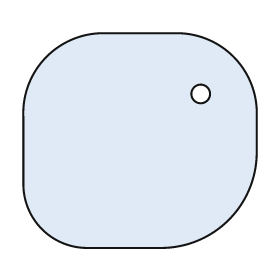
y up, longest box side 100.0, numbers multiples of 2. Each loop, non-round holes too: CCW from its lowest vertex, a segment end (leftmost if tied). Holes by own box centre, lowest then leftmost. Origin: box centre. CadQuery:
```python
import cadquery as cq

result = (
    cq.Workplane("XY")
    .moveTo(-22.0, -46.0)
    .lineTo(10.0, -46.0)
    .threePointArc((38.0, -34.0), (50.0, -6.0))
    .lineTo(50.0, 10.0)
    .threePointArc((40.0, 36.0), (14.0, 46.0))
    .lineTo(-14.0, 46.0)
    .threePointArc((-40.0, 36.0), (-50.0, 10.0))
    .lineTo(-50.0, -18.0)
    .threePointArc((-42.0, -38.0), (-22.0, -46.0))
    .close()
    .moveTo(26.0, 20.0)
    .circle(4.0)
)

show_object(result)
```